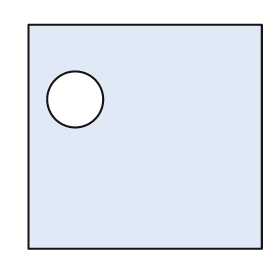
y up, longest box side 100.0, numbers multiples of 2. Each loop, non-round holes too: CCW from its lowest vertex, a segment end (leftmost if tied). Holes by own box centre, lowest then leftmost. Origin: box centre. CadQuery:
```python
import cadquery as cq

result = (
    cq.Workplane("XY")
    .moveTo(-50.0, -48.0)
    .lineTo(50.0, -48.0)
    .lineTo(50.0, 48.0)
    .lineTo(-50.0, 48.0)
    .close()
    .moveTo(-30.0, 16.0)
    .circle(12.0)
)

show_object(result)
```